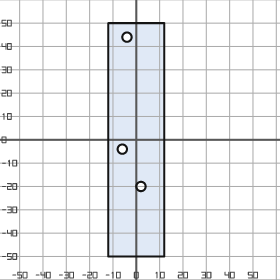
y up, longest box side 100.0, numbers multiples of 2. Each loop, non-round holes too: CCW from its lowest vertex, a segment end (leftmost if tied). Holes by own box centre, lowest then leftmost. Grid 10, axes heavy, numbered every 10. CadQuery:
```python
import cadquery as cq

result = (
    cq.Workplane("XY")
    .moveTo(-12.0, -50.0)
    .lineTo(12.0, -50.0)
    .lineTo(12.0, 50.0)
    .lineTo(-12.0, 50.0)
    .close()
    .moveTo(2.0, -20.0)
    .circle(2.0)
    .moveTo(-6.0, -4.0)
    .circle(2.0)
    .moveTo(-4.0, 44.0)
    .circle(2.0)
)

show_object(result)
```